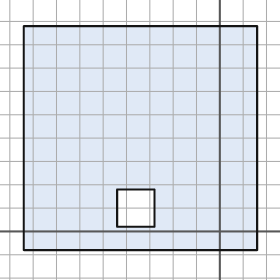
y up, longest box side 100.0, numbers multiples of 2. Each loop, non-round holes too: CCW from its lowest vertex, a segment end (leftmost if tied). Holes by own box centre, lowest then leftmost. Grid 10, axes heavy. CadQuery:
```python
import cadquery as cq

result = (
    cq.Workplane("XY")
    .moveTo(-84.0, -8.0)
    .lineTo(16.0, -8.0)
    .lineTo(16.0, 88.0)
    .lineTo(-84.0, 88.0)
    .close()
    .moveTo(-44.0, 2.0)
    .lineTo(-28.0, 2.0)
    .lineTo(-28.0, 18.0)
    .lineTo(-44.0, 18.0)
    .close()
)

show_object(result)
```